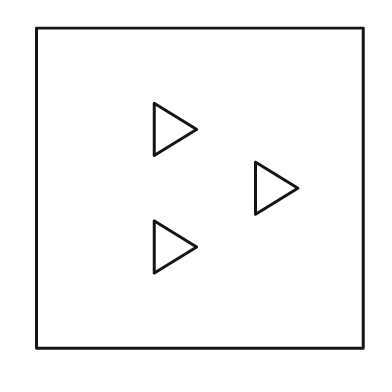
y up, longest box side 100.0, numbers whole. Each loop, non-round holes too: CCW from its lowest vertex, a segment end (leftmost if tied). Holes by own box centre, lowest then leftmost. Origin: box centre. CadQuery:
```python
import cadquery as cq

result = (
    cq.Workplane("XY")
    .moveTo(-50.0, -49.0)
    .lineTo(50.0, -49.0)
    .lineTo(50.0, 49.0)
    .lineTo(-50.0, 49.0)
    .close()
    .moveTo(-14.0, -26.0)
    .lineTo(-1.0, -18.0)
    .lineTo(-14.0, -10.0)
    .close()
    .moveTo(17.0, -8.0)
    .lineTo(30.0, 0.0)
    .lineTo(17.0, 8.0)
    .close()
    .moveTo(-14.0, 10.0)
    .lineTo(-1.0, 18.0)
    .lineTo(-14.0, 26.0)
    .close()
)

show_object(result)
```